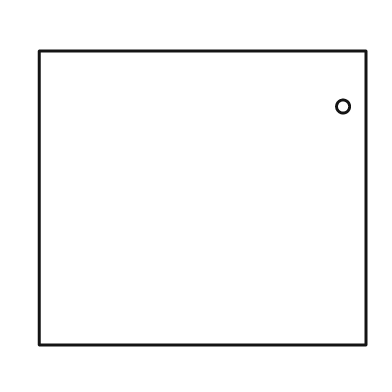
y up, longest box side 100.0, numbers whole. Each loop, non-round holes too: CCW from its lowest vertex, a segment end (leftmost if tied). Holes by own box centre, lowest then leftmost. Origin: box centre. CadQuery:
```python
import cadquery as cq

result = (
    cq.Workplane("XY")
    .moveTo(-50.0, -45.0)
    .lineTo(50.0, -45.0)
    .lineTo(50.0, 45.0)
    .lineTo(-50.0, 45.0)
    .close()
    .moveTo(43.0, 28.0)
    .circle(2.0)
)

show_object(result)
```